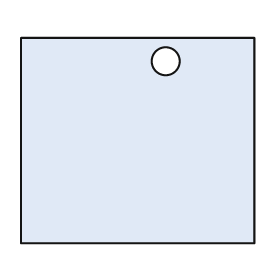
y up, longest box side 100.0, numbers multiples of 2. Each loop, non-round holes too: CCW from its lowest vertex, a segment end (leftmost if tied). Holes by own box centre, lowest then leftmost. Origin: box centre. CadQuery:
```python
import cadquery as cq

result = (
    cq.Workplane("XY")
    .moveTo(-50.0, -44.0)
    .lineTo(50.0, -44.0)
    .lineTo(50.0, 44.0)
    .lineTo(-50.0, 44.0)
    .close()
    .moveTo(12.0, 34.0)
    .circle(6.0)
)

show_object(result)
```